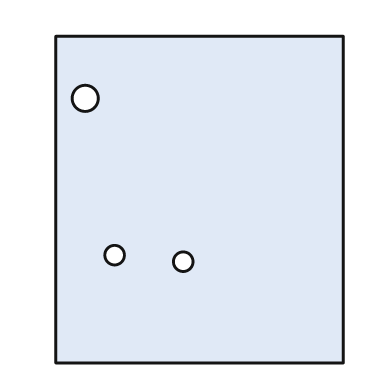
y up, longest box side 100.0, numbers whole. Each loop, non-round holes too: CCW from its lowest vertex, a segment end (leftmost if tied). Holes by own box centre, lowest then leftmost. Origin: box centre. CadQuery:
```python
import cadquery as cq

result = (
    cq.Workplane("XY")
    .moveTo(-44.0, -50.0)
    .lineTo(44.0, -50.0)
    .lineTo(44.0, 50.0)
    .lineTo(-44.0, 50.0)
    .close()
    .moveTo(-5.0, -19.0)
    .circle(3.0)
    .moveTo(-26.0, -17.0)
    .circle(3.0)
    .moveTo(-35.0, 31.0)
    .circle(4.0)
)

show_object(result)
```